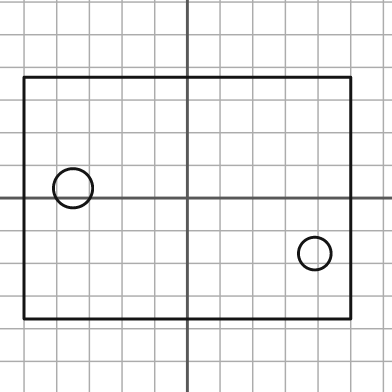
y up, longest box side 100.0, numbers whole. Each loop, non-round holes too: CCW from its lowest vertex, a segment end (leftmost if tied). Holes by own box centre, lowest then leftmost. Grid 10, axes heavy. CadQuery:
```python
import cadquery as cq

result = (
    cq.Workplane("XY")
    .moveTo(-50.0, -37.0)
    .lineTo(50.0, -37.0)
    .lineTo(50.0, 37.0)
    .lineTo(-50.0, 37.0)
    .close()
    .moveTo(39.0, -17.0)
    .circle(5.0)
    .moveTo(-35.0, 3.0)
    .circle(6.0)
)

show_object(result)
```